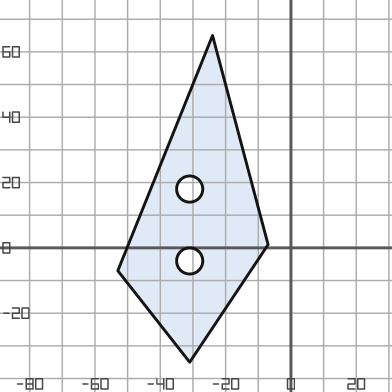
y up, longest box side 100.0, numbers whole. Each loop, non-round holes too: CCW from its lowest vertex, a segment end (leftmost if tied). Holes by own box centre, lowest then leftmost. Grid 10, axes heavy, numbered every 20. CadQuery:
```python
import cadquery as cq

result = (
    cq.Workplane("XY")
    .moveTo(-31.0, -35.0)
    .lineTo(-7.0, 1.0)
    .lineTo(-24.0, 65.0)
    .lineTo(-53.0, -7.0)
    .close()
    .moveTo(-31.0, -4.0)
    .circle(4.0)
    .moveTo(-31.0, 18.0)
    .circle(4.0)
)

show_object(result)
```